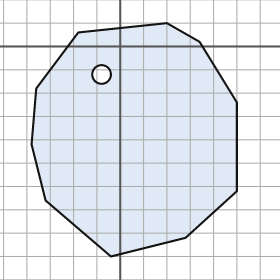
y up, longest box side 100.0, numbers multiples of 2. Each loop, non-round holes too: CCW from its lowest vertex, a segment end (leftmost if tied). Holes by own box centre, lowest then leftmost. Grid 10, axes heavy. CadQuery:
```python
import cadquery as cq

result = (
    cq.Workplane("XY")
    .moveTo(-4.0, -90.0)
    .lineTo(28.0, -82.0)
    .lineTo(50.0, -62.0)
    .lineTo(50.0, -24.0)
    .lineTo(34.0, 2.0)
    .lineTo(20.0, 10.0)
    .lineTo(-18.0, 6.0)
    .lineTo(-36.0, -18.0)
    .lineTo(-38.0, -42.0)
    .lineTo(-32.0, -66.0)
    .close()
    .moveTo(-8.0, -12.0)
    .circle(4.0)
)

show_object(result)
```